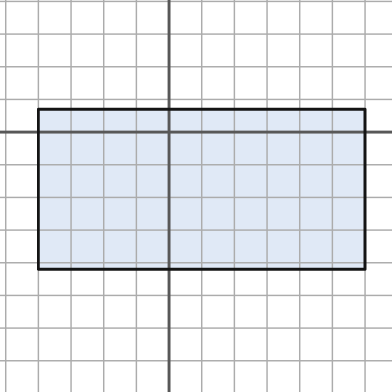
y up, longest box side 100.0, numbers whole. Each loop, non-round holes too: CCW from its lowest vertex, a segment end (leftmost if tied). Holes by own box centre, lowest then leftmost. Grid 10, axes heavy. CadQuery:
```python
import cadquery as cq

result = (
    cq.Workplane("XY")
    .moveTo(-40.0, -42.0)
    .lineTo(60.0, -42.0)
    .lineTo(60.0, 7.0)
    .lineTo(-40.0, 7.0)
    .close()
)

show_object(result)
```